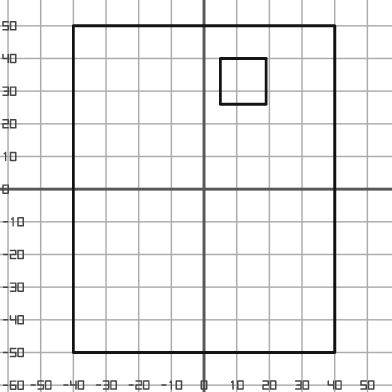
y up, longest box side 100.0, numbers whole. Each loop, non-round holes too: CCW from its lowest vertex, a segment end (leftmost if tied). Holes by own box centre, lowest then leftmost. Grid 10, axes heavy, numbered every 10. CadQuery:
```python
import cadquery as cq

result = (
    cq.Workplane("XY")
    .moveTo(-40.0, -50.0)
    .lineTo(40.0, -50.0)
    .lineTo(40.0, 50.0)
    .lineTo(-40.0, 50.0)
    .close()
    .moveTo(5.0, 26.0)
    .lineTo(19.0, 26.0)
    .lineTo(19.0, 40.0)
    .lineTo(5.0, 40.0)
    .close()
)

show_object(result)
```